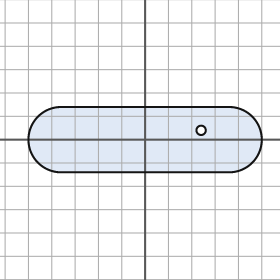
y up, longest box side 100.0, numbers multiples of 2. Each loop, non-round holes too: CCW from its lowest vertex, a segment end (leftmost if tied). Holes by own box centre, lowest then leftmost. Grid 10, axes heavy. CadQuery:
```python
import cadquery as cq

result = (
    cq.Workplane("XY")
    .moveTo(-36.0, -14.0)
    .lineTo(36.0, -14.0)
    .threePointArc((50.0, 0.0), (36.0, 14.0))
    .lineTo(-36.0, 14.0)
    .threePointArc((-50.0, 0.0), (-36.0, -14.0))
    .close()
    .moveTo(24.0, 4.0)
    .circle(2.0)
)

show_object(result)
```